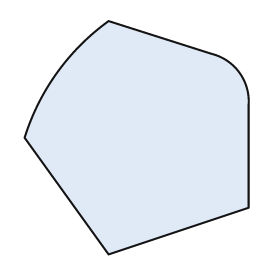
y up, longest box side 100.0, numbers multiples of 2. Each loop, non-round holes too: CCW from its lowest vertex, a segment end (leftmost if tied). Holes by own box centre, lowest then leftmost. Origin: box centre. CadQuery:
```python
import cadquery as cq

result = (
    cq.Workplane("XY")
    .moveTo(-12.0, -50.0)
    .lineTo(48.0, -30.0)
    .lineTo(48.0, 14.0)
    .threePointArc((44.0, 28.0), (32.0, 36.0))
    .lineTo(-12.0, 50.0)
    .threePointArc((-34.0, 28.0), (-48.0, 0.0))
    .close()
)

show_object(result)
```